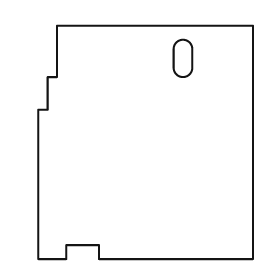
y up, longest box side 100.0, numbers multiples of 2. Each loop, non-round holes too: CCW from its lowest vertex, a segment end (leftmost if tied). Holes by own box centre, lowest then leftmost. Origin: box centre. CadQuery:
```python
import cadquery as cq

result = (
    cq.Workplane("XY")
    .moveTo(-46.0, -50.0)
    .lineTo(-34.0, -50.0)
    .lineTo(-34.0, -44.0)
    .lineTo(-20.0, -44.0)
    .lineTo(-20.0, -50.0)
    .lineTo(46.0, -50.0)
    .lineTo(46.0, 50.0)
    .lineTo(-38.0, 50.0)
    .lineTo(-38.0, 28.0)
    .lineTo(-42.0, 28.0)
    .lineTo(-42.0, 14.0)
    .lineTo(-46.0, 14.0)
    .close()
    .moveTo(12.0, 32.0)
    .threePointArc((16.0, 28.0), (20.0, 32.0))
    .lineTo(20.0, 40.0)
    .threePointArc((16.0, 44.0), (12.0, 40.0))
    .close()
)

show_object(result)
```